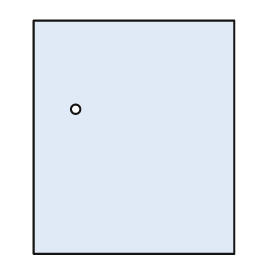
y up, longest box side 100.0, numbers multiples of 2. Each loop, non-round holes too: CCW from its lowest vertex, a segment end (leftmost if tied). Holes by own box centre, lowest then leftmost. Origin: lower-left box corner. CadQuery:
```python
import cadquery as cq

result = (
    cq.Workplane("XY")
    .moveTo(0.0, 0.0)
    .lineTo(86.0, 0.0)
    .lineTo(86.0, 100.0)
    .lineTo(0.0, 100.0)
    .close()
    .moveTo(18.0, 62.0)
    .circle(2.0)
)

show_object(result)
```